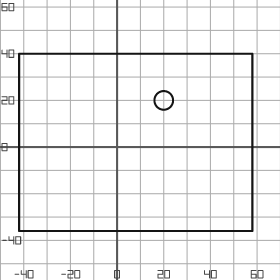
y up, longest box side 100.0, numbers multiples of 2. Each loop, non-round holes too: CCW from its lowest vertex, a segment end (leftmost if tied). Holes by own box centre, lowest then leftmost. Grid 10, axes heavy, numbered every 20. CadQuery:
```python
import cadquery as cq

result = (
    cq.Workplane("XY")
    .moveTo(-42.0, -36.0)
    .lineTo(58.0, -36.0)
    .lineTo(58.0, 40.0)
    .lineTo(-42.0, 40.0)
    .close()
    .moveTo(20.0, 20.0)
    .circle(4.0)
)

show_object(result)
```